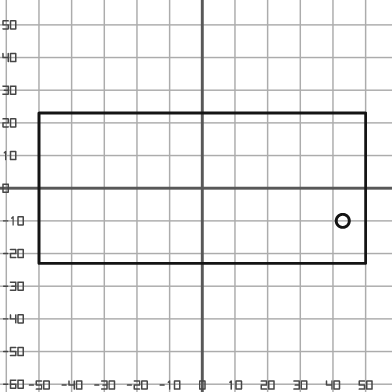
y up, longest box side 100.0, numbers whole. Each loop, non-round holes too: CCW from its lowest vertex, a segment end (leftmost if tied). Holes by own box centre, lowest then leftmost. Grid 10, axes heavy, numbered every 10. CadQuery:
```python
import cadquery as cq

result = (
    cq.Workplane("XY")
    .moveTo(-50.0, -23.0)
    .lineTo(50.0, -23.0)
    .lineTo(50.0, 23.0)
    .lineTo(-50.0, 23.0)
    .close()
    .moveTo(43.0, -10.0)
    .circle(2.0)
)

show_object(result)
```